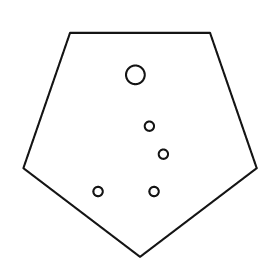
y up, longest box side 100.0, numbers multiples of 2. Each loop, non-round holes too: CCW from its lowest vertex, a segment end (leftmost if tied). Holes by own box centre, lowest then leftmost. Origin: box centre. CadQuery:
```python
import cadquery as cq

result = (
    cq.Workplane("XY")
    .moveTo(0.0, -48.0)
    .lineTo(50.0, -10.0)
    .lineTo(30.0, 48.0)
    .lineTo(-30.0, 48.0)
    .lineTo(-50.0, -10.0)
    .close()
    .moveTo(-18.0, -20.0)
    .circle(2.0)
    .moveTo(6.0, -20.0)
    .circle(2.0)
    .moveTo(10.0, -4.0)
    .circle(2.0)
    .moveTo(4.0, 8.0)
    .circle(2.0)
    .moveTo(-2.0, 30.0)
    .circle(4.0)
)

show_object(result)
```